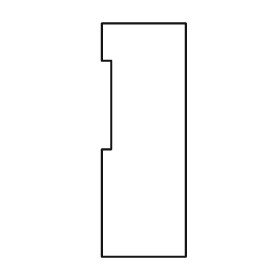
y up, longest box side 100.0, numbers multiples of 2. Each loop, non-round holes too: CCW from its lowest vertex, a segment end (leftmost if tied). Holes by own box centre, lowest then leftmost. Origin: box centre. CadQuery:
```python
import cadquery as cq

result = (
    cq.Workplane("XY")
    .moveTo(-18.0, -50.0)
    .lineTo(18.0, -50.0)
    .lineTo(18.0, 50.0)
    .lineTo(-18.0, 50.0)
    .lineTo(-18.0, 34.0)
    .lineTo(-14.0, 34.0)
    .lineTo(-14.0, -4.0)
    .lineTo(-18.0, -4.0)
    .close()
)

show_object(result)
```